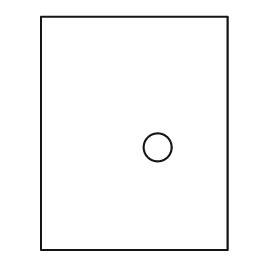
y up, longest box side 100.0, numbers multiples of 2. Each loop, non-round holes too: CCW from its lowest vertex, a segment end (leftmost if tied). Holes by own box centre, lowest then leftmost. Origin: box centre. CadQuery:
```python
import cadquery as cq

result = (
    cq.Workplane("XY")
    .moveTo(-40.0, -50.0)
    .lineTo(40.0, -50.0)
    .lineTo(40.0, 50.0)
    .lineTo(-40.0, 50.0)
    .close()
    .moveTo(10.0, -6.0)
    .circle(6.0)
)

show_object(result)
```